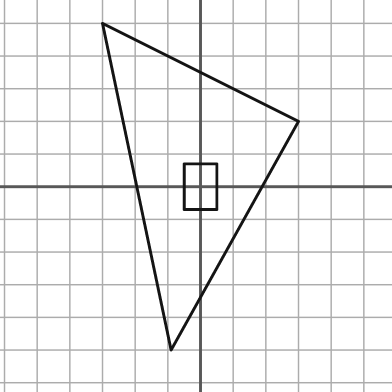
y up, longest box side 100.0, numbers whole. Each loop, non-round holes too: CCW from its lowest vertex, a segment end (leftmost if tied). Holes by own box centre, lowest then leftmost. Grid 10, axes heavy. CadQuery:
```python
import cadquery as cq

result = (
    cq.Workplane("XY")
    .moveTo(-9.0, -50.0)
    .lineTo(30.0, 20.0)
    .lineTo(-30.0, 50.0)
    .close()
    .moveTo(-5.0, -7.0)
    .lineTo(5.0, -7.0)
    .lineTo(5.0, 7.0)
    .lineTo(-5.0, 7.0)
    .close()
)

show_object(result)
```